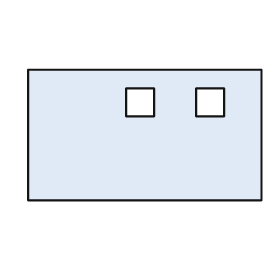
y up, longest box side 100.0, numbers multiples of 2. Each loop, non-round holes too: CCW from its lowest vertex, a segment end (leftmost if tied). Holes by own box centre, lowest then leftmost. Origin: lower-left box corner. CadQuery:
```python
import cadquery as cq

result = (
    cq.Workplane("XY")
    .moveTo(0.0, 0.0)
    .lineTo(100.0, 0.0)
    .lineTo(100.0, 56.0)
    .lineTo(0.0, 56.0)
    .close()
    .moveTo(42.0, 36.0)
    .lineTo(54.0, 36.0)
    .lineTo(54.0, 48.0)
    .lineTo(42.0, 48.0)
    .close()
    .moveTo(72.0, 36.0)
    .lineTo(84.0, 36.0)
    .lineTo(84.0, 48.0)
    .lineTo(72.0, 48.0)
    .close()
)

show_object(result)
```